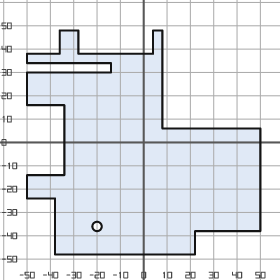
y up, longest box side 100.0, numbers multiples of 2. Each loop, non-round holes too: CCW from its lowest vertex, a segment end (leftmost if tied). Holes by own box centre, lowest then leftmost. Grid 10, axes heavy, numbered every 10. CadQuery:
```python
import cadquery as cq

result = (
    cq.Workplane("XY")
    .moveTo(-38.0, -48.0)
    .lineTo(22.0, -48.0)
    .lineTo(22.0, -38.0)
    .lineTo(50.0, -38.0)
    .lineTo(50.0, 6.0)
    .lineTo(8.0, 6.0)
    .lineTo(8.0, 48.0)
    .lineTo(4.0, 48.0)
    .lineTo(4.0, 38.0)
    .lineTo(-28.0, 38.0)
    .lineTo(-28.0, 48.0)
    .lineTo(-36.0, 48.0)
    .lineTo(-36.0, 38.0)
    .lineTo(-50.0, 38.0)
    .lineTo(-50.0, 34.0)
    .lineTo(-14.0, 34.0)
    .lineTo(-14.0, 30.0)
    .lineTo(-50.0, 30.0)
    .lineTo(-50.0, 16.0)
    .lineTo(-34.0, 16.0)
    .lineTo(-34.0, -14.0)
    .lineTo(-50.0, -14.0)
    .lineTo(-50.0, -24.0)
    .lineTo(-38.0, -24.0)
    .close()
    .moveTo(-20.0, -36.0)
    .circle(2.0)
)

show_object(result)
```